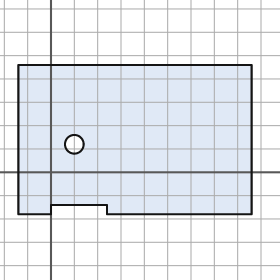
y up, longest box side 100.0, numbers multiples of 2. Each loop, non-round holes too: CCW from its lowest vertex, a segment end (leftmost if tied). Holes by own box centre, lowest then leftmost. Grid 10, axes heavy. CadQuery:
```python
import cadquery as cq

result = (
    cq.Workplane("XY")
    .moveTo(-14.0, -18.0)
    .lineTo(0.0, -18.0)
    .lineTo(0.0, -14.0)
    .lineTo(24.0, -14.0)
    .lineTo(24.0, -18.0)
    .lineTo(86.0, -18.0)
    .lineTo(86.0, 46.0)
    .lineTo(-14.0, 46.0)
    .close()
    .moveTo(10.0, 12.0)
    .circle(4.0)
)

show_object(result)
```